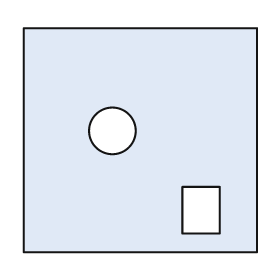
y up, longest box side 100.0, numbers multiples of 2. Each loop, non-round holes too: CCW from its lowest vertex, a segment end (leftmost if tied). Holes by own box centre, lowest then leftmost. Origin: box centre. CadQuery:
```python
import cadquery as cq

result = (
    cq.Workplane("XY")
    .moveTo(-50.0, -48.0)
    .lineTo(50.0, -48.0)
    .lineTo(50.0, 48.0)
    .lineTo(-50.0, 48.0)
    .close()
    .moveTo(18.0, -40.0)
    .lineTo(34.0, -40.0)
    .lineTo(34.0, -20.0)
    .lineTo(18.0, -20.0)
    .close()
    .moveTo(-12.0, 4.0)
    .circle(10.0)
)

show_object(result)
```